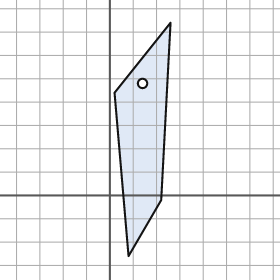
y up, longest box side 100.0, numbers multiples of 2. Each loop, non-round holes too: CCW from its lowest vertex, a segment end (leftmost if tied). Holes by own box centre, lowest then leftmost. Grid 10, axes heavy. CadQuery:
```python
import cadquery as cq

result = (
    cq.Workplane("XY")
    .moveTo(8.0, -26.0)
    .lineTo(22.0, -2.0)
    .lineTo(26.0, 74.0)
    .lineTo(2.0, 44.0)
    .close()
    .moveTo(14.0, 48.0)
    .circle(2.0)
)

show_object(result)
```